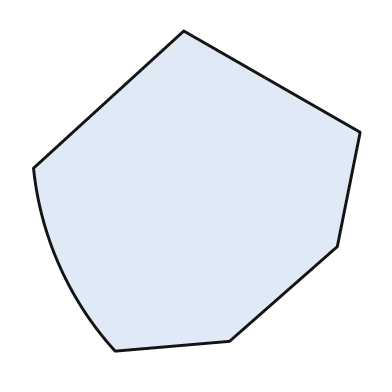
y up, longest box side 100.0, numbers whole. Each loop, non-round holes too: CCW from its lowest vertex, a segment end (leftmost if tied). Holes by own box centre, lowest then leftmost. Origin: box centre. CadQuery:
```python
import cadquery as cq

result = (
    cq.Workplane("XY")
    .moveTo(-25.0, -49.0)
    .lineTo(10.0, -46.0)
    .lineTo(43.0, -17.0)
    .lineTo(50.0, 18.0)
    .lineTo(-4.0, 49.0)
    .lineTo(-50.0, 7.0)
    .threePointArc((-42.0, -23.0), (-25.0, -49.0))
    .close()
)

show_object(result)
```